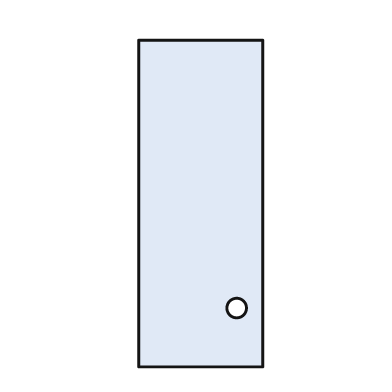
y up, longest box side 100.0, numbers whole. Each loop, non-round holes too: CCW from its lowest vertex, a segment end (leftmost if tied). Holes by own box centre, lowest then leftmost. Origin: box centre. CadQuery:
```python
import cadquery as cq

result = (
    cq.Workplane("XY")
    .moveTo(-19.0, -50.0)
    .lineTo(19.0, -50.0)
    .lineTo(19.0, 50.0)
    .lineTo(-19.0, 50.0)
    .close()
    .moveTo(11.0, -32.0)
    .circle(3.0)
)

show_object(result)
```